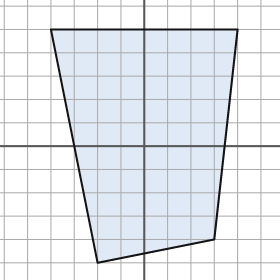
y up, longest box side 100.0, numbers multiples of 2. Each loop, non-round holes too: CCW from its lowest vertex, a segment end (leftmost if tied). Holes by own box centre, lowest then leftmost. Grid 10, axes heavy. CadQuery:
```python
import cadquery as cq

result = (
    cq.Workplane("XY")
    .moveTo(-20.0, -50.0)
    .lineTo(30.0, -40.0)
    .lineTo(40.0, 50.0)
    .lineTo(-40.0, 50.0)
    .close()
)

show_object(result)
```